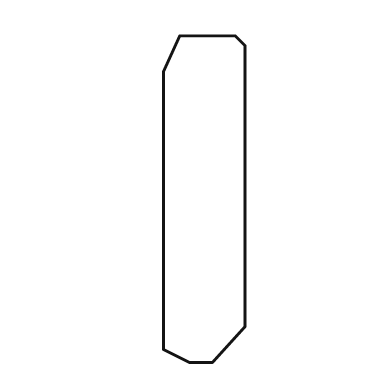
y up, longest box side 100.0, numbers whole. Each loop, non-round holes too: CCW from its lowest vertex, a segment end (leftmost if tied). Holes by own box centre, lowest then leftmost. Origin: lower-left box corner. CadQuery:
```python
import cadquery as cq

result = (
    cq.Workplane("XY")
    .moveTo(8.0, 0.0)
    .lineTo(15.0, 0.0)
    .lineTo(25.0, 11.0)
    .lineTo(25.0, 97.0)
    .lineTo(22.0, 100.0)
    .lineTo(5.0, 100.0)
    .lineTo(0.0, 89.0)
    .lineTo(0.0, 4.0)
    .close()
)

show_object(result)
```